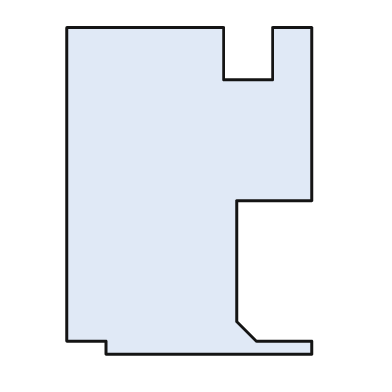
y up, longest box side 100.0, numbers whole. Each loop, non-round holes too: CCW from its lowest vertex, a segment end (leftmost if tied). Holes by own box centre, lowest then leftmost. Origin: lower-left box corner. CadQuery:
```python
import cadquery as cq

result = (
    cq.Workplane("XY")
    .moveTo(12.0, 0.0)
    .lineTo(75.0, 0.0)
    .lineTo(75.0, 4.0)
    .lineTo(58.0, 4.0)
    .lineTo(52.0, 10.0)
    .lineTo(52.0, 47.0)
    .lineTo(75.0, 47.0)
    .lineTo(75.0, 100.0)
    .lineTo(63.0, 100.0)
    .lineTo(63.0, 84.0)
    .lineTo(48.0, 84.0)
    .lineTo(48.0, 100.0)
    .lineTo(0.0, 100.0)
    .lineTo(0.0, 4.0)
    .lineTo(12.0, 4.0)
    .close()
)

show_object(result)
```